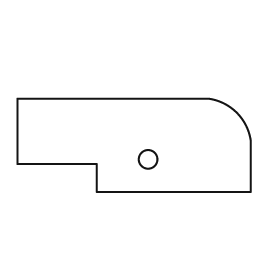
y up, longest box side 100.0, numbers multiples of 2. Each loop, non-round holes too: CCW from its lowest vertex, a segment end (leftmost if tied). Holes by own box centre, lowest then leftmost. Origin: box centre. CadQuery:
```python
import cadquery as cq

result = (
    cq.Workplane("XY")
    .moveTo(-16.0, -20.0)
    .lineTo(50.0, -20.0)
    .lineTo(50.0, 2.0)
    .threePointArc((44.0, 14.0), (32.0, 20.0))
    .lineTo(-50.0, 20.0)
    .lineTo(-50.0, -8.0)
    .lineTo(-16.0, -8.0)
    .close()
    .moveTo(6.0, -6.0)
    .circle(4.0)
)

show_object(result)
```